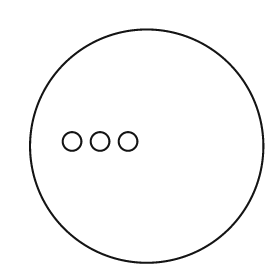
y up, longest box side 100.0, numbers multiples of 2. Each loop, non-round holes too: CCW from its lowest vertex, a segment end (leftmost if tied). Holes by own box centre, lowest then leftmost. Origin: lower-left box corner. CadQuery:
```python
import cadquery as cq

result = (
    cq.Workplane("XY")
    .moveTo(50.0, 50.0)
    .circle(50.0)
    .moveTo(18.0, 52.0)
    .circle(4.0)
    .moveTo(30.0, 52.0)
    .circle(4.0)
    .moveTo(42.0, 52.0)
    .circle(4.0)
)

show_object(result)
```